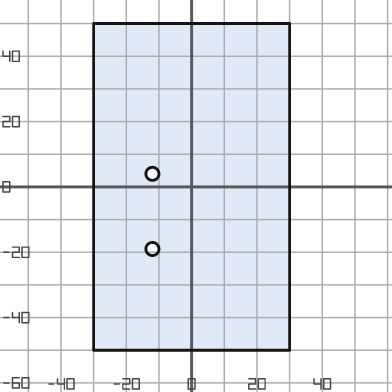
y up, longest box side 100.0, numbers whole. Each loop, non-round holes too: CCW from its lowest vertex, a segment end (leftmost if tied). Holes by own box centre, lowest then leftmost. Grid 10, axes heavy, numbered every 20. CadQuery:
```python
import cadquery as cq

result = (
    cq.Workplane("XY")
    .moveTo(-30.0, -50.0)
    .lineTo(30.0, -50.0)
    .lineTo(30.0, 50.0)
    .lineTo(-30.0, 50.0)
    .close()
    .moveTo(-12.0, -19.0)
    .circle(2.0)
    .moveTo(-12.0, 4.0)
    .circle(2.0)
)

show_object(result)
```